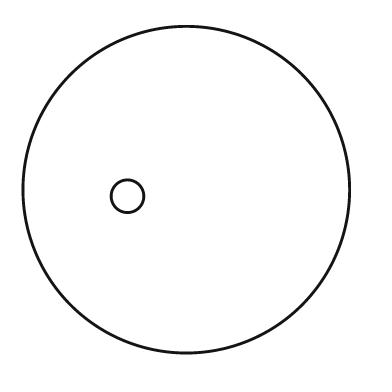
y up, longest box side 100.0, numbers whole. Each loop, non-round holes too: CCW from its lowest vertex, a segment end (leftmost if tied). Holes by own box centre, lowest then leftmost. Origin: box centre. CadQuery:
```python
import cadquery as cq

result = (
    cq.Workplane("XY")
    .moveTo(0.0, 0.0)
    .circle(50.0)
    .moveTo(-18.0, -2.0)
    .circle(5.0)
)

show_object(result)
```